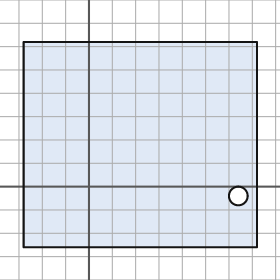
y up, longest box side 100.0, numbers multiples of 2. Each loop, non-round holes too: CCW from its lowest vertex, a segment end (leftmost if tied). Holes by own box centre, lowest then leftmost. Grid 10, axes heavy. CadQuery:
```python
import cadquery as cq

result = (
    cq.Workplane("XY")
    .moveTo(-28.0, -26.0)
    .lineTo(72.0, -26.0)
    .lineTo(72.0, 62.0)
    .lineTo(-28.0, 62.0)
    .close()
    .moveTo(64.0, -4.0)
    .circle(4.0)
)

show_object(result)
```